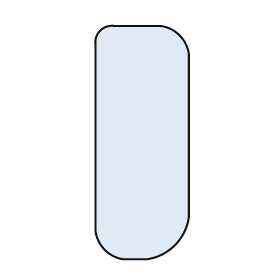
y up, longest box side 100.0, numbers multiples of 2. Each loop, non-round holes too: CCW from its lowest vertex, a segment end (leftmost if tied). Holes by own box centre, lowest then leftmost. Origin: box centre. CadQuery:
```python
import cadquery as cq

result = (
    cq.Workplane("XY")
    .moveTo(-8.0, -50.0)
    .lineTo(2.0, -50.0)
    .threePointArc((14.0, -44.0), (20.0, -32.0))
    .lineTo(20.0, 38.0)
    .threePointArc((16.0, 46.0), (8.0, 50.0))
    .lineTo(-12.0, 50.0)
    .threePointArc((-18.0, 48.0), (-20.0, 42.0))
    .lineTo(-20.0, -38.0)
    .threePointArc((-16.0, -46.0), (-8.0, -50.0))
    .close()
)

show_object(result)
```